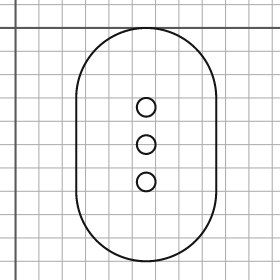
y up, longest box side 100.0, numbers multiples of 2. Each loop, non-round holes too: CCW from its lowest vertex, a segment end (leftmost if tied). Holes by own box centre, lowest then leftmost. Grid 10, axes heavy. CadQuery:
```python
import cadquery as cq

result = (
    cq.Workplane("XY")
    .moveTo(26.0, -70.0)
    .threePointArc((56.0, -100.0), (86.0, -70.0))
    .lineTo(86.0, -30.0)
    .threePointArc((56.0, 0.0), (26.0, -30.0))
    .close()
    .moveTo(56.0, -66.0)
    .circle(4.0)
    .moveTo(56.0, -50.0)
    .circle(4.0)
    .moveTo(56.0, -34.0)
    .circle(4.0)
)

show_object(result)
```